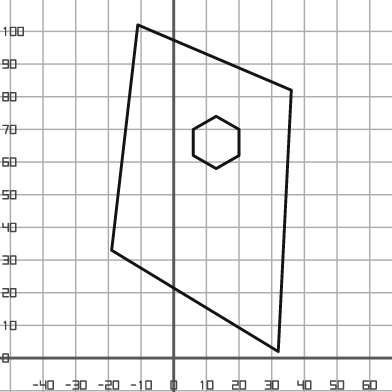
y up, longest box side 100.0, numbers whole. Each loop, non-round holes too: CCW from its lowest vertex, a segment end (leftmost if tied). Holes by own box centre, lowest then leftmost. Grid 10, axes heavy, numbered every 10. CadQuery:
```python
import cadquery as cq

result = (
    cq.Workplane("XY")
    .moveTo(32.0, 2.0)
    .lineTo(36.0, 82.0)
    .lineTo(-11.0, 102.0)
    .lineTo(-19.0, 33.0)
    .close()
    .moveTo(13.0, 58.0)
    .lineTo(20.0, 62.0)
    .lineTo(20.0, 70.0)
    .lineTo(13.0, 74.0)
    .lineTo(6.0, 70.0)
    .lineTo(6.0, 62.0)
    .close()
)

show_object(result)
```